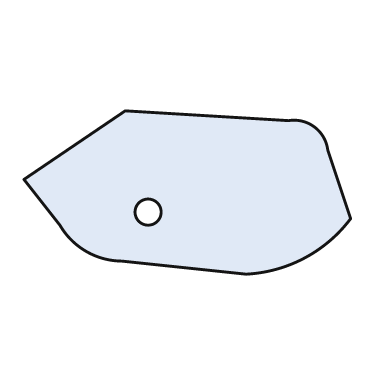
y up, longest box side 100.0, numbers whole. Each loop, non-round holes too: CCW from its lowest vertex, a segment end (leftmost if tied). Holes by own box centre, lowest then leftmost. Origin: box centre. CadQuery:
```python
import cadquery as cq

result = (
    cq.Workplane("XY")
    .moveTo(18.0, -25.0)
    .threePointArc((36.0, -20.0), (50.0, -8.0))
    .lineTo(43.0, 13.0)
    .threePointArc((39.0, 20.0), (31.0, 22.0))
    .lineTo(-19.0, 25.0)
    .lineTo(-50.0, 4.0)
    .lineTo(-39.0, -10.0)
    .threePointArc((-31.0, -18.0), (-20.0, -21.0))
    .close()
    .moveTo(-12.0, -6.0)
    .circle(4.0)
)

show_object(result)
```